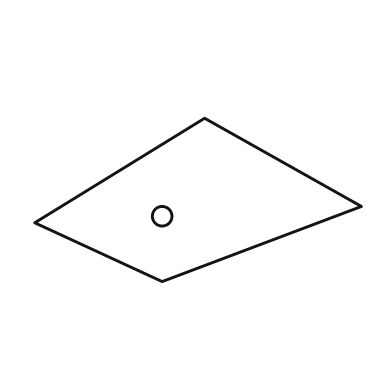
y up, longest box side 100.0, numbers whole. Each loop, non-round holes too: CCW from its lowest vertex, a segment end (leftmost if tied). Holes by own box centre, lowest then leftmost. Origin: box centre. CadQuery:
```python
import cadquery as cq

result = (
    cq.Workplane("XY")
    .moveTo(-11.0, -25.0)
    .lineTo(50.0, -2.0)
    .lineTo(2.0, 25.0)
    .lineTo(-50.0, -7.0)
    .close()
    .moveTo(-11.0, -5.0)
    .circle(3.0)
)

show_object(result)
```